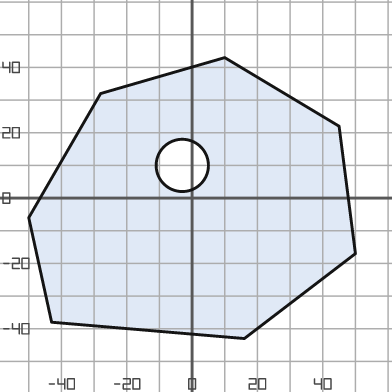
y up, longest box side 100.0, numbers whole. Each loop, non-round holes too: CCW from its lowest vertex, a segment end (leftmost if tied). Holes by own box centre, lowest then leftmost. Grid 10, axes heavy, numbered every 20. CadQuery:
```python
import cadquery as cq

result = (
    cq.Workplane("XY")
    .moveTo(16.0, -43.0)
    .lineTo(50.0, -17.0)
    .lineTo(45.0, 22.0)
    .lineTo(10.0, 43.0)
    .lineTo(-28.0, 32.0)
    .lineTo(-50.0, -6.0)
    .lineTo(-43.0, -38.0)
    .close()
    .moveTo(-3.0, 10.0)
    .circle(8.0)
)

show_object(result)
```